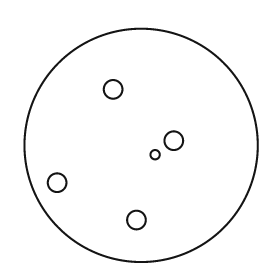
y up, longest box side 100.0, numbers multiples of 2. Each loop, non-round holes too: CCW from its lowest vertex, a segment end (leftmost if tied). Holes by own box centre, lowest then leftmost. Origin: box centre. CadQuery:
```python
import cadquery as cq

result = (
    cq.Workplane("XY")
    .moveTo(0.0, 0.0)
    .circle(50.0)
    .moveTo(-2.0, -32.0)
    .circle(4.0)
    .moveTo(-36.0, -16.0)
    .circle(4.0)
    .moveTo(6.0, -4.0)
    .circle(2.0)
    .moveTo(14.0, 2.0)
    .circle(4.0)
    .moveTo(-12.0, 24.0)
    .circle(4.0)
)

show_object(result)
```